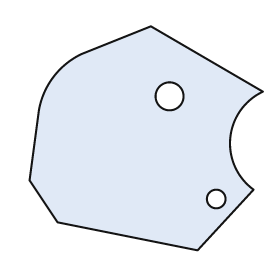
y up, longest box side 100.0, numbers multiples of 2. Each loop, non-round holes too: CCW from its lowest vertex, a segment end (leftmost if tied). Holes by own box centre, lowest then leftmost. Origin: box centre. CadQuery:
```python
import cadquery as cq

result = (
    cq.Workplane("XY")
    .moveTo(22.0, -48.0)
    .lineTo(46.0, -22.0)
    .threePointArc((36.0, 0.0), (50.0, 20.0))
    .lineTo(2.0, 48.0)
    .lineTo(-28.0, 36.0)
    .threePointArc((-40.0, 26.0), (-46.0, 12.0))
    .lineTo(-50.0, -18.0)
    .lineTo(-38.0, -36.0)
    .close()
    .moveTo(30.0, -26.0)
    .circle(4.0)
    .moveTo(10.0, 18.0)
    .circle(6.0)
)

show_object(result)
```